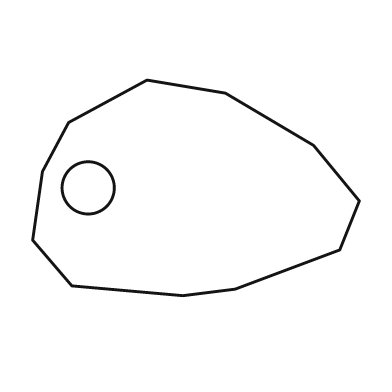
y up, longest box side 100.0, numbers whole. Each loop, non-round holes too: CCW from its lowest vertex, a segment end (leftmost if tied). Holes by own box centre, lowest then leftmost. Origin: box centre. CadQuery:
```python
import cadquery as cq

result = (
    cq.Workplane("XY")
    .moveTo(-4.0, -33.0)
    .lineTo(12.0, -31.0)
    .lineTo(44.0, -19.0)
    .lineTo(50.0, -4.0)
    .lineTo(36.0, 13.0)
    .lineTo(9.0, 29.0)
    .lineTo(-15.0, 33.0)
    .lineTo(-39.0, 20.0)
    .lineTo(-47.0, 5.0)
    .lineTo(-50.0, -16.0)
    .lineTo(-38.0, -30.0)
    .close()
    .moveTo(-33.0, 0.0)
    .circle(8.0)
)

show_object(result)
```